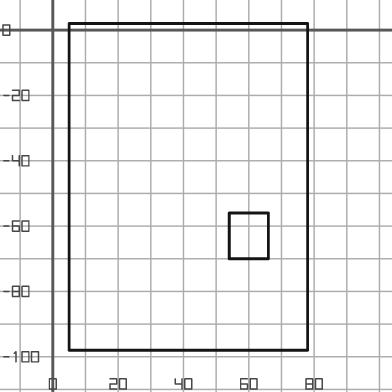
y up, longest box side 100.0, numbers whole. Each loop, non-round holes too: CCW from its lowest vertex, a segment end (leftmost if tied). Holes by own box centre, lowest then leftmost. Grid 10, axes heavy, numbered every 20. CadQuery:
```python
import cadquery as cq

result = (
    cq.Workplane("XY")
    .moveTo(5.0, -98.0)
    .lineTo(78.0, -98.0)
    .lineTo(78.0, 2.0)
    .lineTo(5.0, 2.0)
    .close()
    .moveTo(54.0, -70.0)
    .lineTo(66.0, -70.0)
    .lineTo(66.0, -56.0)
    .lineTo(54.0, -56.0)
    .close()
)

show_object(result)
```